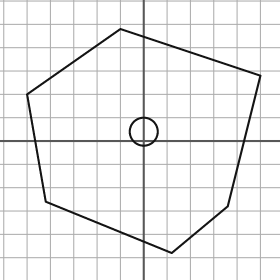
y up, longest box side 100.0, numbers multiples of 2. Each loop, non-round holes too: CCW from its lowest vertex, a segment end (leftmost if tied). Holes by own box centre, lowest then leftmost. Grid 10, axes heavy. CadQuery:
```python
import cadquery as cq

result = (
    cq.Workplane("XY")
    .moveTo(12.0, -48.0)
    .lineTo(36.0, -28.0)
    .lineTo(50.0, 28.0)
    .lineTo(-10.0, 48.0)
    .lineTo(-50.0, 20.0)
    .lineTo(-42.0, -26.0)
    .close()
    .moveTo(0.0, 4.0)
    .circle(6.0)
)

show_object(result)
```